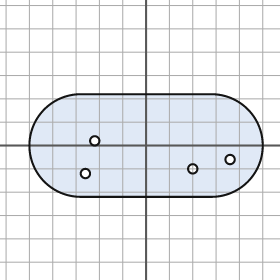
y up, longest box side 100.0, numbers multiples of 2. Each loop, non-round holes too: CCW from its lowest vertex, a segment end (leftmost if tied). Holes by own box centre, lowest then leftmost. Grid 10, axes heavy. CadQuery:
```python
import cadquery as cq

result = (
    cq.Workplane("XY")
    .moveTo(-28.0, -22.0)
    .lineTo(28.0, -22.0)
    .threePointArc((50.0, 0.0), (28.0, 22.0))
    .lineTo(-28.0, 22.0)
    .threePointArc((-50.0, 0.0), (-28.0, -22.0))
    .close()
    .moveTo(-26.0, -12.0)
    .circle(2.0)
    .moveTo(20.0, -10.0)
    .circle(2.0)
    .moveTo(36.0, -6.0)
    .circle(2.0)
    .moveTo(-22.0, 2.0)
    .circle(2.0)
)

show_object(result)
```